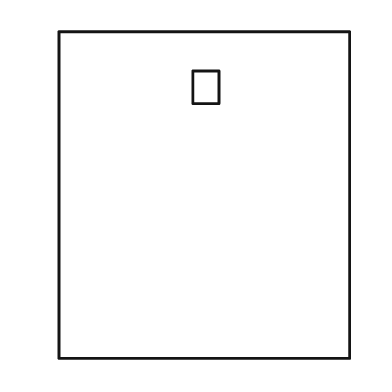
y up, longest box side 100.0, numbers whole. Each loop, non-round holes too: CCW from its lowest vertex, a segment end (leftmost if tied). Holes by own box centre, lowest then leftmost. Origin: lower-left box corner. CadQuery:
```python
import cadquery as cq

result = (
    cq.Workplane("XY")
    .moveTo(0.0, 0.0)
    .lineTo(89.0, 0.0)
    .lineTo(89.0, 100.0)
    .lineTo(0.0, 100.0)
    .close()
    .moveTo(41.0, 78.0)
    .lineTo(49.0, 78.0)
    .lineTo(49.0, 88.0)
    .lineTo(41.0, 88.0)
    .close()
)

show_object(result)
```